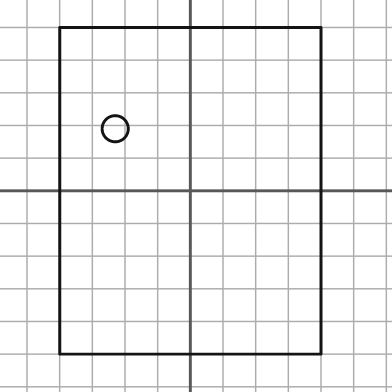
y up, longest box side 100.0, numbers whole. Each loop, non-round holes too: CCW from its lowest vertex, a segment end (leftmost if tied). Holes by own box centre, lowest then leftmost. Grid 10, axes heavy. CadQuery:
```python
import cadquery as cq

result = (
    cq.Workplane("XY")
    .moveTo(-40.0, -50.0)
    .lineTo(40.0, -50.0)
    .lineTo(40.0, 50.0)
    .lineTo(-40.0, 50.0)
    .close()
    .moveTo(-23.0, 19.0)
    .circle(4.0)
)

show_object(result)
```